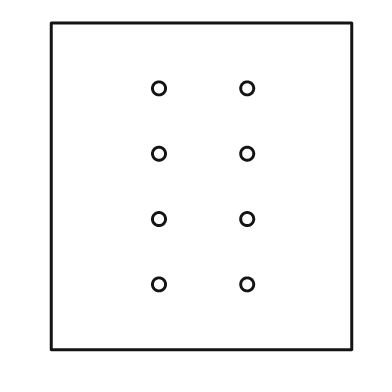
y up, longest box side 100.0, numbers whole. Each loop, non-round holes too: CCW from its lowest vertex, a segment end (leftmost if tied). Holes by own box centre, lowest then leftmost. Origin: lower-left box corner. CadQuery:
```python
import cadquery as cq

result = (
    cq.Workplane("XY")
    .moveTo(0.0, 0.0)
    .lineTo(92.0, 0.0)
    .lineTo(92.0, 100.0)
    .lineTo(0.0, 100.0)
    .close()
    .moveTo(33.0, 20.0)
    .circle(2.0)
    .moveTo(60.0, 20.0)
    .circle(2.0)
    .moveTo(33.0, 40.0)
    .circle(2.0)
    .moveTo(60.0, 40.0)
    .circle(2.0)
    .moveTo(33.0, 60.0)
    .circle(2.0)
    .moveTo(60.0, 60.0)
    .circle(2.0)
    .moveTo(33.0, 80.0)
    .circle(2.0)
    .moveTo(60.0, 80.0)
    .circle(2.0)
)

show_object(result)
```